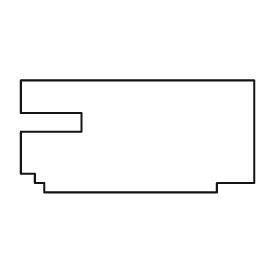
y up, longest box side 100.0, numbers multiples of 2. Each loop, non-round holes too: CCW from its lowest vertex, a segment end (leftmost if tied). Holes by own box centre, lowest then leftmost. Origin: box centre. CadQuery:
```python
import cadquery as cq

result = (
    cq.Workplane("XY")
    .moveTo(-40.0, -24.0)
    .lineTo(34.0, -24.0)
    .lineTo(34.0, -20.0)
    .lineTo(50.0, -20.0)
    .lineTo(50.0, 24.0)
    .lineTo(-50.0, 24.0)
    .lineTo(-50.0, 10.0)
    .lineTo(-24.0, 10.0)
    .lineTo(-24.0, 2.0)
    .lineTo(-50.0, 2.0)
    .lineTo(-50.0, -16.0)
    .lineTo(-44.0, -16.0)
    .lineTo(-44.0, -20.0)
    .lineTo(-40.0, -20.0)
    .close()
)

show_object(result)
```